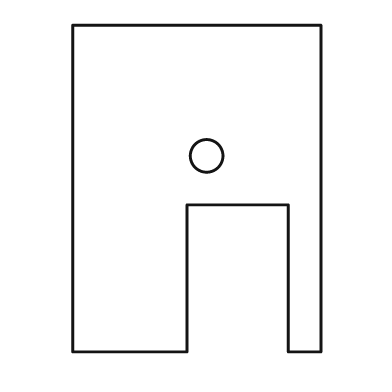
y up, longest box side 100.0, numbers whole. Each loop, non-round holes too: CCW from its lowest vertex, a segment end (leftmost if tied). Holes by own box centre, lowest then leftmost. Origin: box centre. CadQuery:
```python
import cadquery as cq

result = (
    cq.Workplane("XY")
    .moveTo(-38.0, -50.0)
    .lineTo(-3.0, -50.0)
    .lineTo(-3.0, -5.0)
    .lineTo(28.0, -5.0)
    .lineTo(28.0, -50.0)
    .lineTo(38.0, -50.0)
    .lineTo(38.0, 50.0)
    .lineTo(-38.0, 50.0)
    .close()
    .moveTo(3.0, 10.0)
    .circle(5.0)
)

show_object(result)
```